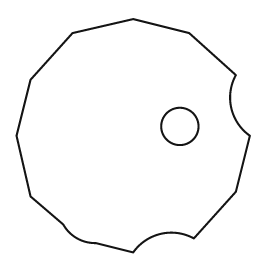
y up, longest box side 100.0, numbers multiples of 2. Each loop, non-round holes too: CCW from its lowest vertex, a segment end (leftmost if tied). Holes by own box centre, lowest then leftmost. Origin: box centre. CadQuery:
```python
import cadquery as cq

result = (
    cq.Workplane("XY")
    .moveTo(0.0, -50.0)
    .threePointArc((12.0, -42.0), (26.0, -44.0))
    .lineTo(44.0, -24.0)
    .lineTo(50.0, 0.0)
    .threePointArc((42.0, 12.0), (44.0, 26.0))
    .lineTo(24.0, 44.0)
    .lineTo(0.0, 50.0)
    .lineTo(-26.0, 44.0)
    .lineTo(-44.0, 24.0)
    .lineTo(-50.0, 0.0)
    .lineTo(-44.0, -26.0)
    .lineTo(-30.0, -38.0)
    .threePointArc((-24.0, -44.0), (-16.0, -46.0))
    .close()
    .moveTo(20.0, 4.0)
    .circle(8.0)
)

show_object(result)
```